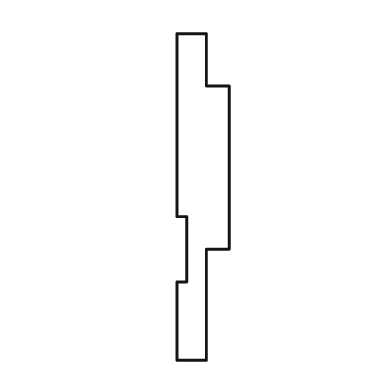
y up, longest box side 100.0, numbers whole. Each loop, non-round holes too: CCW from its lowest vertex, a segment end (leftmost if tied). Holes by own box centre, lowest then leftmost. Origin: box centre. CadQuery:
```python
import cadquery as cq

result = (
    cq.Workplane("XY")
    .moveTo(-8.0, -50.0)
    .lineTo(1.0, -50.0)
    .lineTo(1.0, -16.0)
    .lineTo(8.0, -16.0)
    .lineTo(8.0, 34.0)
    .lineTo(1.0, 34.0)
    .lineTo(1.0, 50.0)
    .lineTo(-8.0, 50.0)
    .lineTo(-8.0, -6.0)
    .lineTo(-5.0, -6.0)
    .lineTo(-5.0, -26.0)
    .lineTo(-8.0, -26.0)
    .close()
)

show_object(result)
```